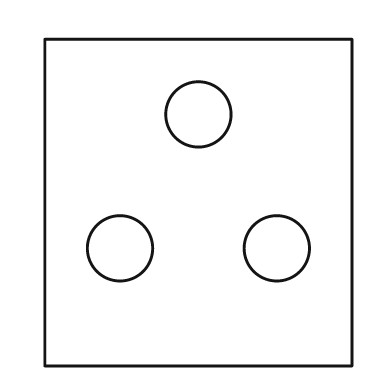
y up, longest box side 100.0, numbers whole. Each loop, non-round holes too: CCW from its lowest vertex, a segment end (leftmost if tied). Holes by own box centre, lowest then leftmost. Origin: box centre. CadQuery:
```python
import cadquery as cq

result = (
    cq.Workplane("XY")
    .moveTo(-47.0, -50.0)
    .lineTo(47.0, -50.0)
    .lineTo(47.0, 50.0)
    .lineTo(-47.0, 50.0)
    .close()
    .moveTo(-24.0, -14.0)
    .circle(10.0)
    .moveTo(24.0, -14.0)
    .circle(10.0)
    .moveTo(0.0, 27.0)
    .circle(10.0)
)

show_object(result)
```